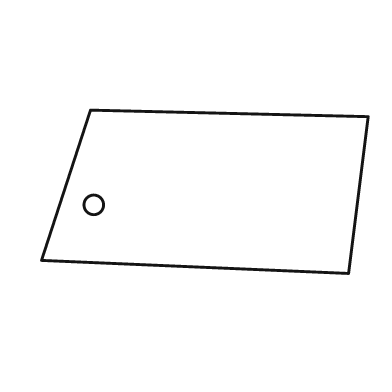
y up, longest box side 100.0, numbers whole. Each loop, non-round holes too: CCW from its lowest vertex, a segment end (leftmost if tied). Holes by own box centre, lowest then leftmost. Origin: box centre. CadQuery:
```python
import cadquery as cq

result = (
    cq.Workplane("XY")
    .moveTo(44.0, -25.0)
    .lineTo(50.0, 23.0)
    .lineTo(-35.0, 25.0)
    .lineTo(-50.0, -21.0)
    .close()
    .moveTo(-34.0, -4.0)
    .circle(3.0)
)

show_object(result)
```